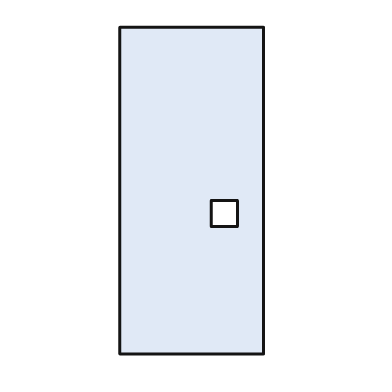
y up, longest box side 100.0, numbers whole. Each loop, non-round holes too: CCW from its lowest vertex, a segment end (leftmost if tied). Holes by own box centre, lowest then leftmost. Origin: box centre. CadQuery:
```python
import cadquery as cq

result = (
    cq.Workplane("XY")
    .moveTo(-22.0, -50.0)
    .lineTo(22.0, -50.0)
    .lineTo(22.0, 50.0)
    .lineTo(-22.0, 50.0)
    .close()
    .moveTo(6.0, -11.0)
    .lineTo(14.0, -11.0)
    .lineTo(14.0, -3.0)
    .lineTo(6.0, -3.0)
    .close()
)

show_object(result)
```